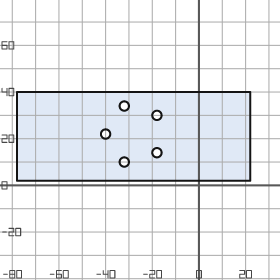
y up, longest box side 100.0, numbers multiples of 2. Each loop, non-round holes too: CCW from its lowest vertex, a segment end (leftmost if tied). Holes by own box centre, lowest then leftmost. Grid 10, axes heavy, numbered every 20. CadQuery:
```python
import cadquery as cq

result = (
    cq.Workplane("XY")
    .moveTo(-78.0, 2.0)
    .lineTo(22.0, 2.0)
    .lineTo(22.0, 40.0)
    .lineTo(-78.0, 40.0)
    .close()
    .moveTo(-32.0, 10.0)
    .circle(2.0)
    .moveTo(-18.0, 14.0)
    .circle(2.0)
    .moveTo(-40.0, 22.0)
    .circle(2.0)
    .moveTo(-18.0, 30.0)
    .circle(2.0)
    .moveTo(-32.0, 34.0)
    .circle(2.0)
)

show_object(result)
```